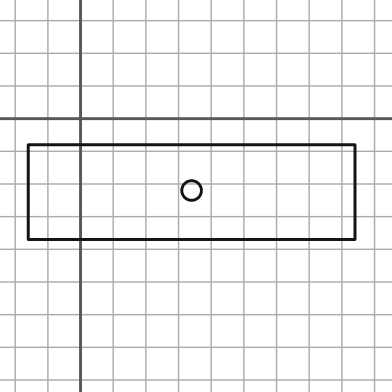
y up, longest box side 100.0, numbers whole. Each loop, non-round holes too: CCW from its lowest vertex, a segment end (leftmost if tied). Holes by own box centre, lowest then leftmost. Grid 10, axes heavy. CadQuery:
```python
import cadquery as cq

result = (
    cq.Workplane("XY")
    .moveTo(-16.0, -37.0)
    .lineTo(84.0, -37.0)
    .lineTo(84.0, -8.0)
    .lineTo(-16.0, -8.0)
    .close()
    .moveTo(34.0, -22.0)
    .circle(3.0)
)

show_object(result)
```